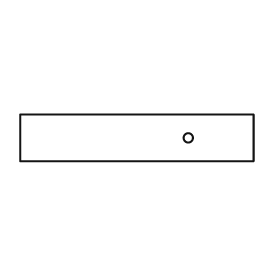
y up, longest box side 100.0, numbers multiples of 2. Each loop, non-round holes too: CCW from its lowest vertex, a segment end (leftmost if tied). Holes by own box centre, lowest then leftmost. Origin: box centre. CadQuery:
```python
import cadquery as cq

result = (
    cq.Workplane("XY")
    .moveTo(-50.0, -10.0)
    .lineTo(50.0, -10.0)
    .lineTo(50.0, 10.0)
    .lineTo(-50.0, 10.0)
    .close()
    .moveTo(22.0, 0.0)
    .circle(2.0)
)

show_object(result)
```